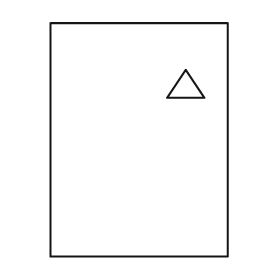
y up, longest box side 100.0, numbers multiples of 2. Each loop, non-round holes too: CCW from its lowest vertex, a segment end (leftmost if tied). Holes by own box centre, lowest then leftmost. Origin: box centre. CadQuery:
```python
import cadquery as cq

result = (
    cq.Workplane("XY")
    .moveTo(-38.0, -50.0)
    .lineTo(38.0, -50.0)
    .lineTo(38.0, 50.0)
    .lineTo(-38.0, 50.0)
    .close()
    .moveTo(12.0, 18.0)
    .lineTo(28.0, 18.0)
    .lineTo(20.0, 30.0)
    .close()
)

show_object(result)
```